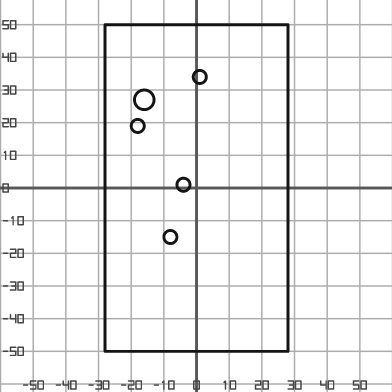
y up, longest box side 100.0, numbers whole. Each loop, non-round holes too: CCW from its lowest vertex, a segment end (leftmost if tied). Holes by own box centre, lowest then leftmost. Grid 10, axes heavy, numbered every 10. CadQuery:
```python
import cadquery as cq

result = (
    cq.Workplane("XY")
    .moveTo(-28.0, -50.0)
    .lineTo(28.0, -50.0)
    .lineTo(28.0, 50.0)
    .lineTo(-28.0, 50.0)
    .close()
    .moveTo(-8.0, -15.0)
    .circle(2.0)
    .moveTo(-4.0, 1.0)
    .circle(2.0)
    .moveTo(-18.0, 19.0)
    .circle(2.0)
    .moveTo(-16.0, 27.0)
    .circle(3.0)
    .moveTo(1.0, 34.0)
    .circle(2.0)
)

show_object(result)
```